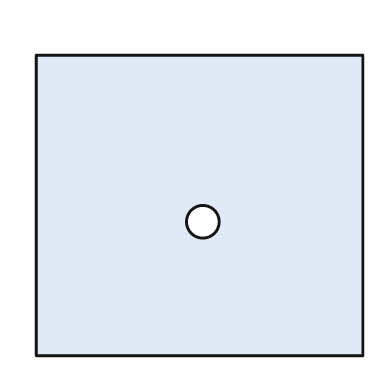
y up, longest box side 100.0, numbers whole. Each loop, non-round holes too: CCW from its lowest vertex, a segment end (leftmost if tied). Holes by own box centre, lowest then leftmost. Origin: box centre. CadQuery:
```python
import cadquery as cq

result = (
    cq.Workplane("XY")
    .moveTo(-50.0, -46.0)
    .lineTo(50.0, -46.0)
    .lineTo(50.0, 46.0)
    .lineTo(-50.0, 46.0)
    .close()
    .moveTo(1.0, -5.0)
    .circle(5.0)
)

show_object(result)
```